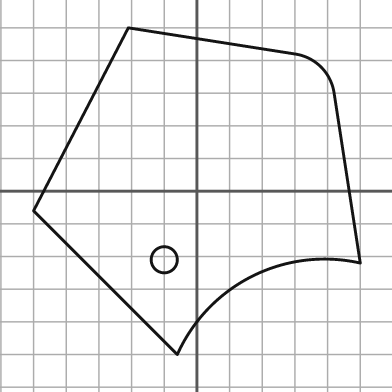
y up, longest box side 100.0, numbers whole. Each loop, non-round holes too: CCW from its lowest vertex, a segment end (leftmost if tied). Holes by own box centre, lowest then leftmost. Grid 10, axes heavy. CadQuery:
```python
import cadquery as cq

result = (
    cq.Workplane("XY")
    .moveTo(-6.0, -50.0)
    .threePointArc((17.0, -26.0), (50.0, -22.0))
    .lineTo(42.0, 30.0)
    .threePointArc((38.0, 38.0), (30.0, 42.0))
    .lineTo(-21.0, 50.0)
    .lineTo(-50.0, -6.0)
    .close()
    .moveTo(-10.0, -21.0)
    .circle(4.0)
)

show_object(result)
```